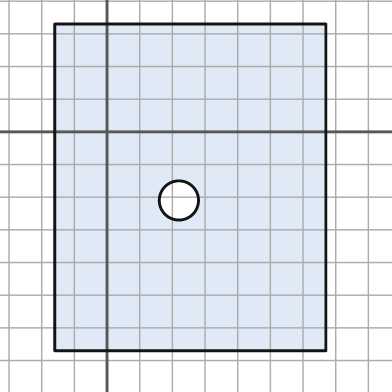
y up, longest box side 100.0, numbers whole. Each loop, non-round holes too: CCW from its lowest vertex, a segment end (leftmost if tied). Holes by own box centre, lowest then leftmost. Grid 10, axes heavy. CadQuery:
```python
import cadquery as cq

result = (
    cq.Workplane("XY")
    .moveTo(-16.0, -67.0)
    .lineTo(67.0, -67.0)
    .lineTo(67.0, 33.0)
    .lineTo(-16.0, 33.0)
    .close()
    .moveTo(22.0, -21.0)
    .circle(6.0)
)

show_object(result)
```